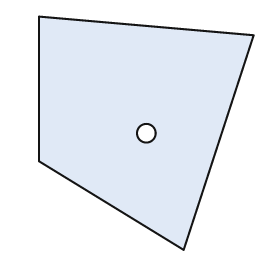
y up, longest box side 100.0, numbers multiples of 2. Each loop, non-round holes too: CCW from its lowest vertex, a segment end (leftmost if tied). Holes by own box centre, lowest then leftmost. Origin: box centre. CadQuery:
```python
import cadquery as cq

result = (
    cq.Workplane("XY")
    .moveTo(16.0, -50.0)
    .lineTo(46.0, 42.0)
    .lineTo(-46.0, 50.0)
    .lineTo(-46.0, -12.0)
    .close()
    .moveTo(0.0, 0.0)
    .circle(4.0)
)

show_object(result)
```